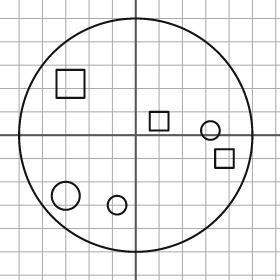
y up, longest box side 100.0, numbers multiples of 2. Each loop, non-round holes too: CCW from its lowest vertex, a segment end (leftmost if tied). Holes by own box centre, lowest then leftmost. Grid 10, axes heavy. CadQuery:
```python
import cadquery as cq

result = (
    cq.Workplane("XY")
    .moveTo(0.0, 0.0)
    .circle(50.0)
    .moveTo(-8.0, -30.0)
    .circle(4.0)
    .moveTo(-30.0, -26.0)
    .circle(6.0)
    .moveTo(34.0, -14.0)
    .lineTo(42.0, -14.0)
    .lineTo(42.0, -6.0)
    .lineTo(34.0, -6.0)
    .close()
    .moveTo(32.0, 2.0)
    .circle(4.0)
    .moveTo(6.0, 2.0)
    .lineTo(14.0, 2.0)
    .lineTo(14.0, 10.0)
    .lineTo(6.0, 10.0)
    .close()
    .moveTo(-34.0, 16.0)
    .lineTo(-22.0, 16.0)
    .lineTo(-22.0, 28.0)
    .lineTo(-34.0, 28.0)
    .close()
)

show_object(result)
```